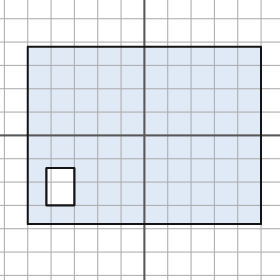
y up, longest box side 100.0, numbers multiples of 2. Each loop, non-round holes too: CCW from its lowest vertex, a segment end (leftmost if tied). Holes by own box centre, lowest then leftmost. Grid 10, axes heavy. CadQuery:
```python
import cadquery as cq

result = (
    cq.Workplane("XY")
    .moveTo(-50.0, -38.0)
    .lineTo(50.0, -38.0)
    .lineTo(50.0, 38.0)
    .lineTo(-50.0, 38.0)
    .close()
    .moveTo(-42.0, -30.0)
    .lineTo(-30.0, -30.0)
    .lineTo(-30.0, -14.0)
    .lineTo(-42.0, -14.0)
    .close()
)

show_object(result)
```